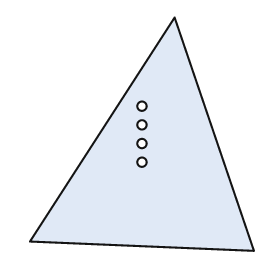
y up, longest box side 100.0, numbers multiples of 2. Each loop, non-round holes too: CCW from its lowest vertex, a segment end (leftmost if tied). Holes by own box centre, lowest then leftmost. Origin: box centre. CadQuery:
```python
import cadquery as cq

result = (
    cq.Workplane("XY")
    .moveTo(48.0, -50.0)
    .lineTo(14.0, 50.0)
    .lineTo(-48.0, -46.0)
    .close()
    .moveTo(0.0, -12.0)
    .circle(2.0)
    .moveTo(0.0, -4.0)
    .circle(2.0)
    .moveTo(0.0, 4.0)
    .circle(2.0)
    .moveTo(0.0, 12.0)
    .circle(2.0)
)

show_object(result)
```